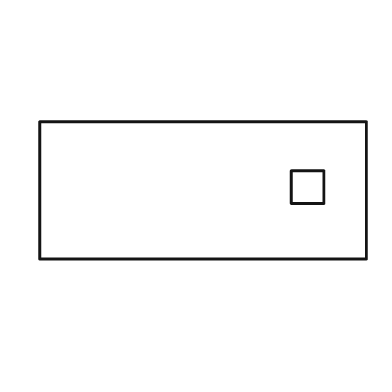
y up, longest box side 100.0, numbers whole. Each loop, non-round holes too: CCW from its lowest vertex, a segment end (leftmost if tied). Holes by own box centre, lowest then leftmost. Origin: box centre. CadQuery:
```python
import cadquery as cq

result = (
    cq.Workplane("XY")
    .moveTo(-50.0, -21.0)
    .lineTo(50.0, -21.0)
    .lineTo(50.0, 21.0)
    .lineTo(-50.0, 21.0)
    .close()
    .moveTo(27.0, -4.0)
    .lineTo(37.0, -4.0)
    .lineTo(37.0, 6.0)
    .lineTo(27.0, 6.0)
    .close()
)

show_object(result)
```